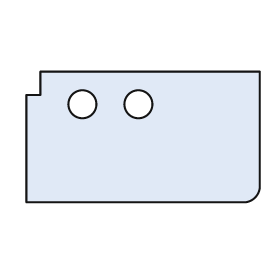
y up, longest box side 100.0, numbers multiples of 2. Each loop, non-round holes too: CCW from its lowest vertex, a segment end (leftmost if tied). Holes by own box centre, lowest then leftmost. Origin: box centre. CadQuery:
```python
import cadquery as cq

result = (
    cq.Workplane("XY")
    .moveTo(-50.0, -28.0)
    .lineTo(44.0, -28.0)
    .threePointArc((48.0, -26.0), (50.0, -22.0))
    .lineTo(50.0, 28.0)
    .lineTo(-44.0, 28.0)
    .lineTo(-44.0, 18.0)
    .lineTo(-50.0, 18.0)
    .close()
    .moveTo(-26.0, 14.0)
    .circle(6.0)
    .moveTo(-2.0, 14.0)
    .circle(6.0)
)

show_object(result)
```